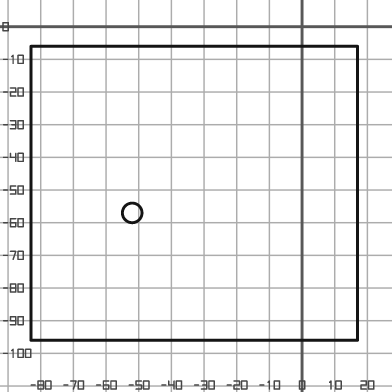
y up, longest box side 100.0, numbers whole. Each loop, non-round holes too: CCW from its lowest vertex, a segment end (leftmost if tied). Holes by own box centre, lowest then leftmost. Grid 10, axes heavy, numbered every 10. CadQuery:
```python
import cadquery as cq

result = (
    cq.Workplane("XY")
    .moveTo(-83.0, -96.0)
    .lineTo(17.0, -96.0)
    .lineTo(17.0, -6.0)
    .lineTo(-83.0, -6.0)
    .close()
    .moveTo(-52.0, -57.0)
    .circle(3.0)
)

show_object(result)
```